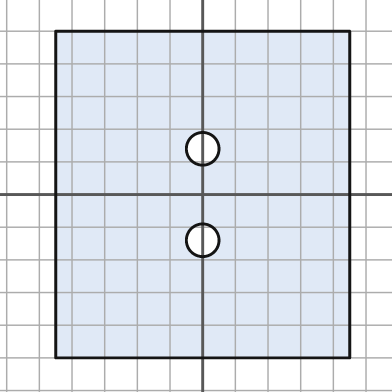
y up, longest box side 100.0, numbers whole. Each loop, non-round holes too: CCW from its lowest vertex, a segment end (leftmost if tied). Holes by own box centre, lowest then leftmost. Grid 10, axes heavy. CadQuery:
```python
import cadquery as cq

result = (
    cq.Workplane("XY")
    .moveTo(-45.0, -50.0)
    .lineTo(45.0, -50.0)
    .lineTo(45.0, 50.0)
    .lineTo(-45.0, 50.0)
    .close()
    .moveTo(0.0, -14.0)
    .circle(5.0)
    .moveTo(0.0, 14.0)
    .circle(5.0)
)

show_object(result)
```